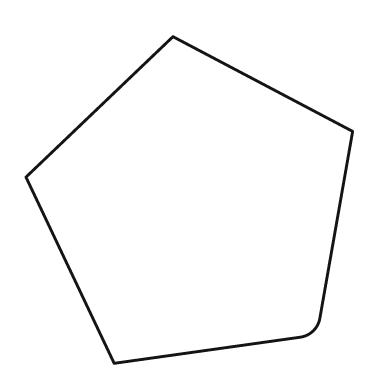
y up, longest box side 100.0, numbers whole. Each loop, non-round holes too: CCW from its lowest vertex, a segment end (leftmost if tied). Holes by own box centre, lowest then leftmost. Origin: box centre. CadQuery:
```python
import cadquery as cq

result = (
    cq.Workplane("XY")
    .moveTo(-23.0, -50.0)
    .lineTo(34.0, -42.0)
    .threePointArc((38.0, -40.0), (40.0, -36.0))
    .lineTo(50.0, 21.0)
    .lineTo(-5.0, 50.0)
    .lineTo(-50.0, 7.0)
    .close()
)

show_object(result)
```